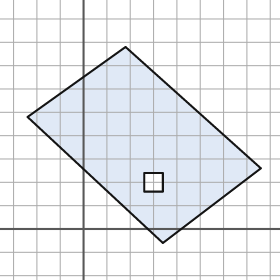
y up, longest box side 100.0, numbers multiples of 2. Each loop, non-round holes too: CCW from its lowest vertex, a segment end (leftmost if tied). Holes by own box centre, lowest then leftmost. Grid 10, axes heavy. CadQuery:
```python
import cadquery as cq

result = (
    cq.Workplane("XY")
    .moveTo(34.0, -6.0)
    .lineTo(76.0, 26.0)
    .lineTo(18.0, 78.0)
    .lineTo(-24.0, 48.0)
    .close()
    .moveTo(26.0, 16.0)
    .lineTo(34.0, 16.0)
    .lineTo(34.0, 24.0)
    .lineTo(26.0, 24.0)
    .close()
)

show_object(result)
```